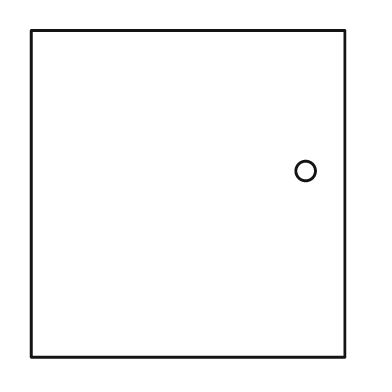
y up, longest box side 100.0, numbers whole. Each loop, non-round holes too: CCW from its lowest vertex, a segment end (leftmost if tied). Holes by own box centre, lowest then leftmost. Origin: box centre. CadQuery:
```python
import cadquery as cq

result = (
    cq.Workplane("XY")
    .moveTo(-48.0, -50.0)
    .lineTo(48.0, -50.0)
    .lineTo(48.0, 50.0)
    .lineTo(-48.0, 50.0)
    .close()
    .moveTo(36.0, 7.0)
    .circle(3.0)
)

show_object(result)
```